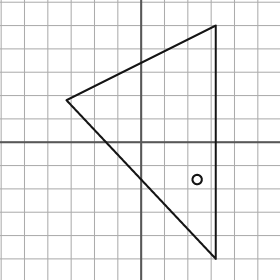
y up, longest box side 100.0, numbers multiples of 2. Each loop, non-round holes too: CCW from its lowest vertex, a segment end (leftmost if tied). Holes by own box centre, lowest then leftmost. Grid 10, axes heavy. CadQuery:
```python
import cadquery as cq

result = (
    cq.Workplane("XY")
    .moveTo(32.0, -50.0)
    .lineTo(32.0, 50.0)
    .lineTo(-32.0, 18.0)
    .close()
    .moveTo(24.0, -16.0)
    .circle(2.0)
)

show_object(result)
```